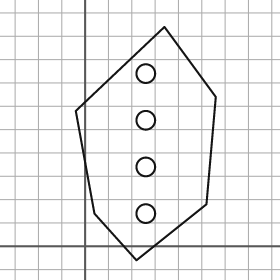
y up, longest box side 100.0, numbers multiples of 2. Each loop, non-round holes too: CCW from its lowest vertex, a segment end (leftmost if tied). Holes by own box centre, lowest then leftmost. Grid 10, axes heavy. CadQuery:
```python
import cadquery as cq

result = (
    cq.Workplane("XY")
    .moveTo(22.0, -6.0)
    .lineTo(52.0, 18.0)
    .lineTo(56.0, 64.0)
    .lineTo(34.0, 94.0)
    .lineTo(-4.0, 58.0)
    .lineTo(4.0, 14.0)
    .close()
    .moveTo(26.0, 14.0)
    .circle(4.0)
    .moveTo(26.0, 34.0)
    .circle(4.0)
    .moveTo(26.0, 54.0)
    .circle(4.0)
    .moveTo(26.0, 74.0)
    .circle(4.0)
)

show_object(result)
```